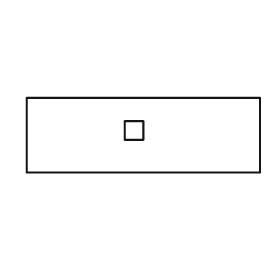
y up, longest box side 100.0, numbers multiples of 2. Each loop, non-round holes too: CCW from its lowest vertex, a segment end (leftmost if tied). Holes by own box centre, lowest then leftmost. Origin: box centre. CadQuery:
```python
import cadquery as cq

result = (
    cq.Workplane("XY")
    .moveTo(-50.0, -16.0)
    .lineTo(50.0, -16.0)
    .lineTo(50.0, 16.0)
    .lineTo(-50.0, 16.0)
    .close()
    .moveTo(-8.0, -2.0)
    .lineTo(0.0, -2.0)
    .lineTo(0.0, 6.0)
    .lineTo(-8.0, 6.0)
    .close()
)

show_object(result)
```